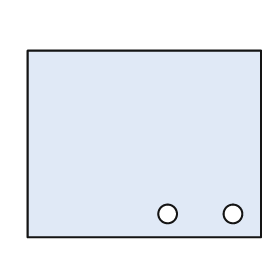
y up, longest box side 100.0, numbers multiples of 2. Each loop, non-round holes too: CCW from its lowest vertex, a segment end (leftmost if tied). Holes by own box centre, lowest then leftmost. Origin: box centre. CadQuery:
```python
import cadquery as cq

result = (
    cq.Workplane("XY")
    .moveTo(-50.0, -40.0)
    .lineTo(50.0, -40.0)
    .lineTo(50.0, 40.0)
    .lineTo(-50.0, 40.0)
    .close()
    .moveTo(10.0, -30.0)
    .circle(4.0)
    .moveTo(38.0, -30.0)
    .circle(4.0)
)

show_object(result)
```